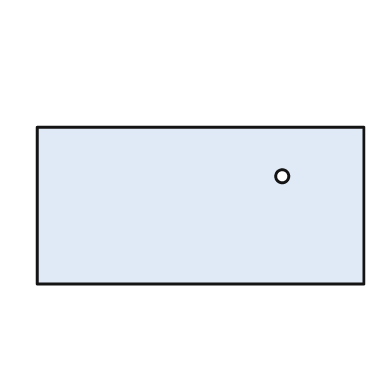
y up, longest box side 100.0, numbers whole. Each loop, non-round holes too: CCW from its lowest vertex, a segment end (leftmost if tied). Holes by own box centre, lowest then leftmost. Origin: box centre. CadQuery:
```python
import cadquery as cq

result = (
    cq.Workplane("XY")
    .moveTo(-50.0, -24.0)
    .lineTo(50.0, -24.0)
    .lineTo(50.0, 24.0)
    .lineTo(-50.0, 24.0)
    .close()
    .moveTo(25.0, 9.0)
    .circle(2.0)
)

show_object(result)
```